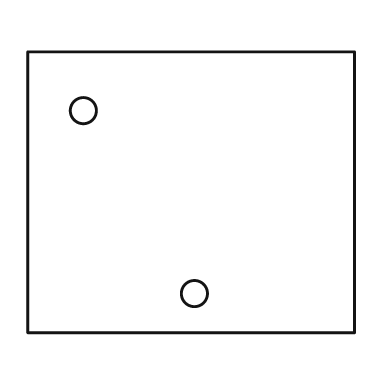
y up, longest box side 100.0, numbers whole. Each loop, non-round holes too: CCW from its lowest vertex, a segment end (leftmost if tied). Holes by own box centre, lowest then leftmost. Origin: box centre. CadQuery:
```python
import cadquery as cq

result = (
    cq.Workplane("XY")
    .moveTo(-50.0, -43.0)
    .lineTo(50.0, -43.0)
    .lineTo(50.0, 43.0)
    .lineTo(-50.0, 43.0)
    .close()
    .moveTo(1.0, -31.0)
    .circle(4.0)
    .moveTo(-33.0, 25.0)
    .circle(4.0)
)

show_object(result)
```